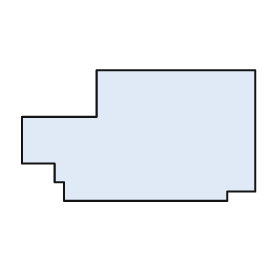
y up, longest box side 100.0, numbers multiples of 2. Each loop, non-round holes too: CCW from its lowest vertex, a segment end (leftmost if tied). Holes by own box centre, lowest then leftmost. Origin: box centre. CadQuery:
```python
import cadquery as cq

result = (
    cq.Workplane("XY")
    .moveTo(-32.0, -28.0)
    .lineTo(38.0, -28.0)
    .lineTo(38.0, -24.0)
    .lineTo(50.0, -24.0)
    .lineTo(50.0, 28.0)
    .lineTo(-18.0, 28.0)
    .lineTo(-18.0, 8.0)
    .lineTo(-50.0, 8.0)
    .lineTo(-50.0, -12.0)
    .lineTo(-36.0, -12.0)
    .lineTo(-36.0, -20.0)
    .lineTo(-32.0, -20.0)
    .close()
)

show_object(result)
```